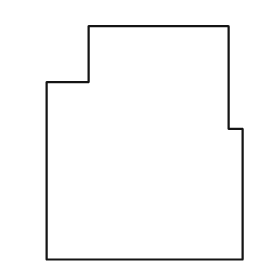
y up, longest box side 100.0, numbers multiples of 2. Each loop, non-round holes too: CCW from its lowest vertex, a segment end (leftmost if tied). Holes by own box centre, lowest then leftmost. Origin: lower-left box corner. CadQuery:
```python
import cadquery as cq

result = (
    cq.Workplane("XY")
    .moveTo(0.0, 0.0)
    .lineTo(84.0, 0.0)
    .lineTo(84.0, 56.0)
    .lineTo(78.0, 56.0)
    .lineTo(78.0, 100.0)
    .lineTo(18.0, 100.0)
    .lineTo(18.0, 76.0)
    .lineTo(0.0, 76.0)
    .close()
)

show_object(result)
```